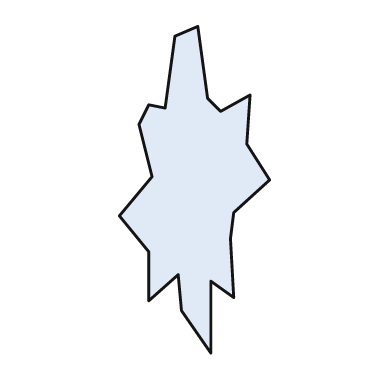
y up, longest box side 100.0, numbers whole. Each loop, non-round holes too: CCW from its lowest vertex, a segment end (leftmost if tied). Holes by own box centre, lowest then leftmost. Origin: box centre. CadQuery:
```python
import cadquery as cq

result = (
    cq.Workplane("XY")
    .moveTo(5.0, -50.0)
    .lineTo(5.0, -28.0)
    .lineTo(12.0, -33.0)
    .lineTo(11.0, -15.0)
    .lineTo(12.0, -7.0)
    .lineTo(23.0, 3.0)
    .lineTo(16.0, 14.0)
    .lineTo(17.0, 29.0)
    .lineTo(8.0, 24.0)
    .lineTo(4.0, 28.0)
    .lineTo(1.0, 50.0)
    .lineTo(-6.0, 47.0)
    .lineTo(-9.0, 25.0)
    .lineTo(-14.0, 26.0)
    .lineTo(-17.0, 20.0)
    .lineTo(-13.0, 4.0)
    .lineTo(-23.0, -8.0)
    .lineTo(-14.0, -19.0)
    .lineTo(-14.0, -34.0)
    .lineTo(-5.0, -26.0)
    .lineTo(-4.0, -37.0)
    .close()
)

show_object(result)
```